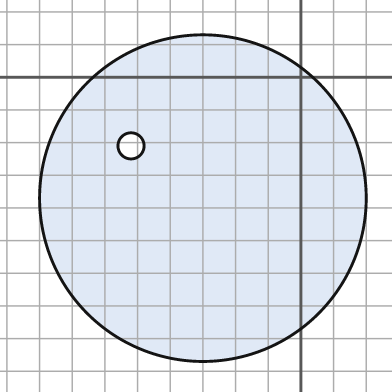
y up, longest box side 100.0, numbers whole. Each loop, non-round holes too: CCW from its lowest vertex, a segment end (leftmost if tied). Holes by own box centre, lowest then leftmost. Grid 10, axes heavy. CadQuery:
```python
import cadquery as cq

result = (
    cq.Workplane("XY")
    .moveTo(-30.0, -37.0)
    .circle(50.0)
    .moveTo(-52.0, -21.0)
    .circle(4.0)
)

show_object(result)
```